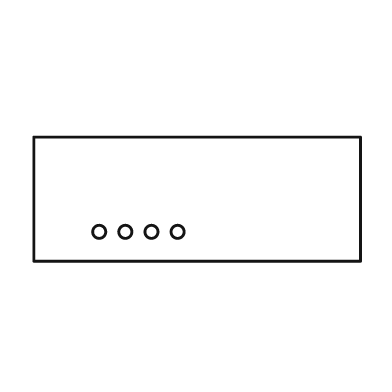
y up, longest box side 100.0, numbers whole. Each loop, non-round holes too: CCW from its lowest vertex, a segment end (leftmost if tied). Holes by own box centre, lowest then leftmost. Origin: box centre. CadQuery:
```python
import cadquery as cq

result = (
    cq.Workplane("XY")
    .moveTo(-50.0, -19.0)
    .lineTo(50.0, -19.0)
    .lineTo(50.0, 19.0)
    .lineTo(-50.0, 19.0)
    .close()
    .moveTo(-30.0, -10.0)
    .circle(2.0)
    .moveTo(-22.0, -10.0)
    .circle(2.0)
    .moveTo(-14.0, -10.0)
    .circle(2.0)
    .moveTo(-6.0, -10.0)
    .circle(2.0)
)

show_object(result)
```